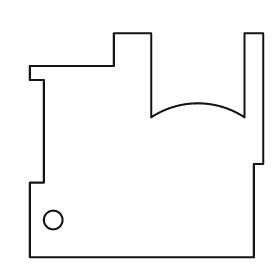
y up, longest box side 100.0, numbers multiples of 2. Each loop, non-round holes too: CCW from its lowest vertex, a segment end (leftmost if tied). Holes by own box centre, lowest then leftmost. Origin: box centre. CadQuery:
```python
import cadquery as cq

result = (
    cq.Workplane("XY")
    .moveTo(-50.0, -48.0)
    .lineTo(46.0, -48.0)
    .lineTo(46.0, -8.0)
    .lineTo(50.0, -8.0)
    .lineTo(50.0, 48.0)
    .lineTo(42.0, 48.0)
    .lineTo(42.0, 12.0)
    .threePointArc((22.0, 18.0), (2.0, 12.0))
    .lineTo(2.0, 48.0)
    .lineTo(-14.0, 48.0)
    .lineTo(-14.0, 34.0)
    .lineTo(-50.0, 34.0)
    .lineTo(-50.0, 28.0)
    .lineTo(-44.0, 28.0)
    .lineTo(-44.0, -16.0)
    .lineTo(-50.0, -16.0)
    .close()
    .moveTo(-40.0, -32.0)
    .circle(4.0)
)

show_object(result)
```